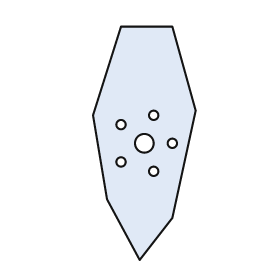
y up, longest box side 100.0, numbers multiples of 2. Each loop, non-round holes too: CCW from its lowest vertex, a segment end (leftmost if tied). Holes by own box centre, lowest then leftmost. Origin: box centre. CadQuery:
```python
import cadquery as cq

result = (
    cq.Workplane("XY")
    .moveTo(-2.0, -50.0)
    .lineTo(12.0, -32.0)
    .lineTo(22.0, 14.0)
    .lineTo(12.0, 50.0)
    .lineTo(-10.0, 50.0)
    .lineTo(-22.0, 12.0)
    .lineTo(-16.0, -24.0)
    .close()
    .moveTo(4.0, -12.0)
    .circle(2.0)
    .moveTo(-10.0, -8.0)
    .circle(2.0)
    .moveTo(0.0, 0.0)
    .circle(4.0)
    .moveTo(12.0, 0.0)
    .circle(2.0)
    .moveTo(-10.0, 8.0)
    .circle(2.0)
    .moveTo(4.0, 12.0)
    .circle(2.0)
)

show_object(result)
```